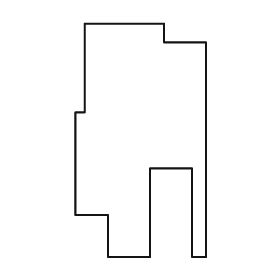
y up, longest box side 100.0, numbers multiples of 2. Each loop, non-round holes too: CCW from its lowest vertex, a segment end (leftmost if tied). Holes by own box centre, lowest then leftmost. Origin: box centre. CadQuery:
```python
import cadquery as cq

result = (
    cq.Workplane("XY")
    .moveTo(-14.0, -50.0)
    .lineTo(4.0, -50.0)
    .lineTo(4.0, -12.0)
    .lineTo(22.0, -12.0)
    .lineTo(22.0, -50.0)
    .lineTo(28.0, -50.0)
    .lineTo(28.0, 42.0)
    .lineTo(10.0, 42.0)
    .lineTo(10.0, 50.0)
    .lineTo(-24.0, 50.0)
    .lineTo(-24.0, 12.0)
    .lineTo(-28.0, 12.0)
    .lineTo(-28.0, -32.0)
    .lineTo(-14.0, -32.0)
    .close()
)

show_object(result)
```